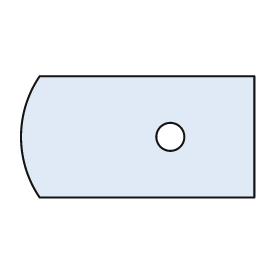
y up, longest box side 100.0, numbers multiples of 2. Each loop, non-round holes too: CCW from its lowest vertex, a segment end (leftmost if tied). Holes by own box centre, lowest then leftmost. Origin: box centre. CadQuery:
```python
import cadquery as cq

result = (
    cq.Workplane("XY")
    .moveTo(-42.0, -26.0)
    .lineTo(50.0, -26.0)
    .lineTo(50.0, 26.0)
    .lineTo(-42.0, 26.0)
    .threePointArc((-50.0, 0.0), (-42.0, -26.0))
    .close()
    .moveTo(14.0, 0.0)
    .circle(6.0)
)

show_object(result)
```